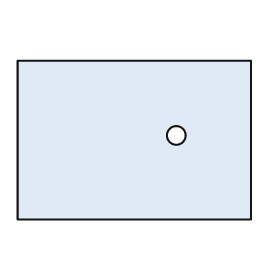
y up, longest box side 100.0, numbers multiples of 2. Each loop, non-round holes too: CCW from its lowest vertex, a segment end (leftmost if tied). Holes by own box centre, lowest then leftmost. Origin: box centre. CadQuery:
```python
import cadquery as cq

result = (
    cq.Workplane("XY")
    .moveTo(-50.0, -34.0)
    .lineTo(50.0, -34.0)
    .lineTo(50.0, 34.0)
    .lineTo(-50.0, 34.0)
    .close()
    .moveTo(18.0, 2.0)
    .circle(4.0)
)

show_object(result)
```